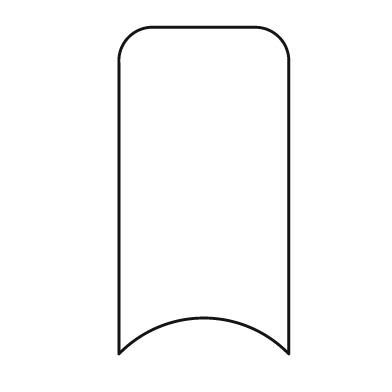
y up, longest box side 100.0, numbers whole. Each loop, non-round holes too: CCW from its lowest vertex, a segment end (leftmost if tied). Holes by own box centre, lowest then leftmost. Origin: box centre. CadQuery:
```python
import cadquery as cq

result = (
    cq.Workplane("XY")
    .moveTo(-26.0, -50.0)
    .threePointArc((0.0, -39.0), (26.0, -50.0))
    .lineTo(26.0, 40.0)
    .threePointArc((23.0, 47.0), (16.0, 50.0))
    .lineTo(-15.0, 50.0)
    .threePointArc((-23.0, 47.0), (-26.0, 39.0))
    .close()
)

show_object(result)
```